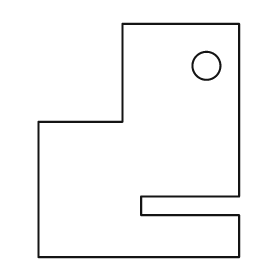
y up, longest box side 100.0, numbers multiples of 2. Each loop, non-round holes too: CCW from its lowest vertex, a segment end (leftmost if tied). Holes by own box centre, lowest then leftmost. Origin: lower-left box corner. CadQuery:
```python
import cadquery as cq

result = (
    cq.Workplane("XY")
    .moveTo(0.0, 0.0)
    .lineTo(86.0, 0.0)
    .lineTo(86.0, 18.0)
    .lineTo(44.0, 18.0)
    .lineTo(44.0, 26.0)
    .lineTo(86.0, 26.0)
    .lineTo(86.0, 100.0)
    .lineTo(36.0, 100.0)
    .lineTo(36.0, 58.0)
    .lineTo(0.0, 58.0)
    .close()
    .moveTo(72.0, 82.0)
    .circle(6.0)
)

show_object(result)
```